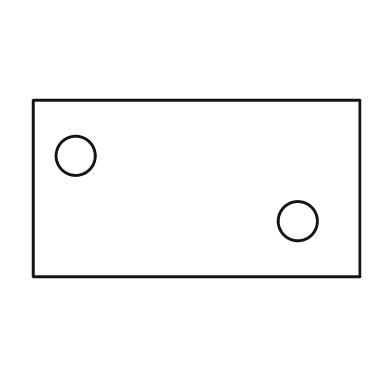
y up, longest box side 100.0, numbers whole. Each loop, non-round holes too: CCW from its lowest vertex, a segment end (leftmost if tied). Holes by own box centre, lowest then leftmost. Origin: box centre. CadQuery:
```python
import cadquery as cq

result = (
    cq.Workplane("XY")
    .moveTo(-50.0, -27.0)
    .lineTo(50.0, -27.0)
    .lineTo(50.0, 27.0)
    .lineTo(-50.0, 27.0)
    .close()
    .moveTo(31.0, -10.0)
    .circle(6.0)
    .moveTo(-37.0, 10.0)
    .circle(6.0)
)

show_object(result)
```